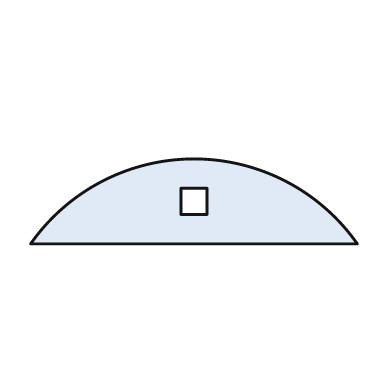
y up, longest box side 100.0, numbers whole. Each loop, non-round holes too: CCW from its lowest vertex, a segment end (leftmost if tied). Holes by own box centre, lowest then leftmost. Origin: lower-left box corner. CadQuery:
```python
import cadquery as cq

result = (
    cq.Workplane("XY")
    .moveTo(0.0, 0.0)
    .lineTo(100.0, 0.0)
    .threePointArc((50.0, 26.0), (0.0, 0.0))
    .close()
    .moveTo(46.0, 9.0)
    .lineTo(54.0, 9.0)
    .lineTo(54.0, 17.0)
    .lineTo(46.0, 17.0)
    .close()
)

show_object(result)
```